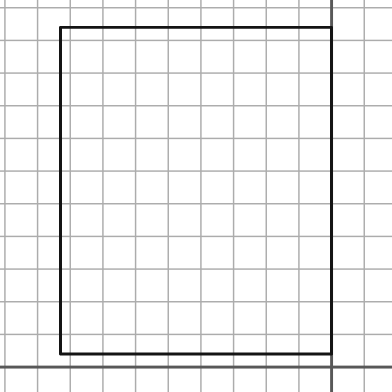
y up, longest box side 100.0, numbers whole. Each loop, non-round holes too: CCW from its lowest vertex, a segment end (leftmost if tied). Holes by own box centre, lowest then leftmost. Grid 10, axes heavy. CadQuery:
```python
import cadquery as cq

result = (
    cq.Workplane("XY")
    .moveTo(-83.0, 4.0)
    .lineTo(0.0, 4.0)
    .lineTo(0.0, 104.0)
    .lineTo(-83.0, 104.0)
    .close()
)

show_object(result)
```